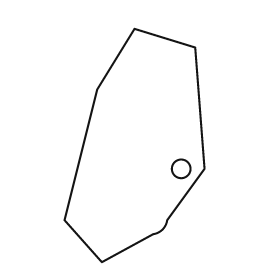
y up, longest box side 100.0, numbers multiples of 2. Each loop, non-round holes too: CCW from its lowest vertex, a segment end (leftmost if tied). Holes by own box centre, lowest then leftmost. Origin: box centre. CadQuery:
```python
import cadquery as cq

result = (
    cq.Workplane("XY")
    .moveTo(-14.0, -50.0)
    .lineTo(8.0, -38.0)
    .threePointArc((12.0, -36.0), (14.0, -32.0))
    .lineTo(30.0, -10.0)
    .lineTo(26.0, 42.0)
    .lineTo(0.0, 50.0)
    .lineTo(-16.0, 24.0)
    .lineTo(-30.0, -32.0)
    .close()
    .moveTo(20.0, -10.0)
    .circle(4.0)
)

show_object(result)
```